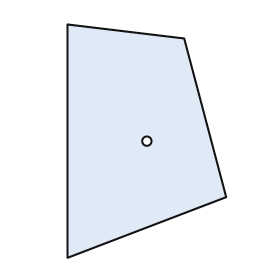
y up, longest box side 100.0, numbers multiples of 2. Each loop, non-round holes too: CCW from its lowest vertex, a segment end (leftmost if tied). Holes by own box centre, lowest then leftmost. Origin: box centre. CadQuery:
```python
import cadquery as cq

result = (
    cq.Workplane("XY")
    .moveTo(-34.0, -50.0)
    .lineTo(34.0, -24.0)
    .lineTo(16.0, 44.0)
    .lineTo(-34.0, 50.0)
    .close()
    .moveTo(0.0, 0.0)
    .circle(2.0)
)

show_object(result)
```